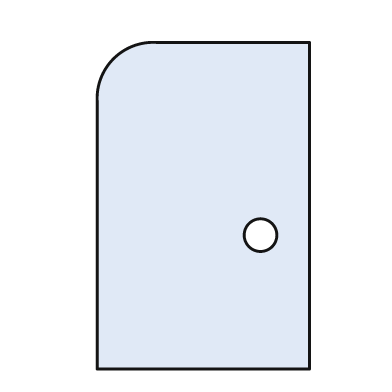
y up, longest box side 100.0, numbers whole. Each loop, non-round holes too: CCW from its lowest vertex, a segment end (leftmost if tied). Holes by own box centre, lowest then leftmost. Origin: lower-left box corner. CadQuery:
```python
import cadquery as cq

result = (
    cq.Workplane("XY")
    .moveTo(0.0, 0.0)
    .lineTo(65.0, 0.0)
    .lineTo(65.0, 100.0)
    .lineTo(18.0, 100.0)
    .threePointArc((5.0, 95.0), (0.0, 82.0))
    .close()
    .moveTo(50.0, 41.0)
    .circle(5.0)
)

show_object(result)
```